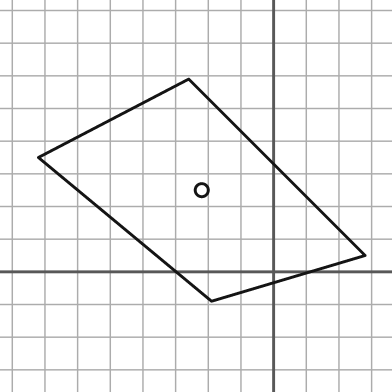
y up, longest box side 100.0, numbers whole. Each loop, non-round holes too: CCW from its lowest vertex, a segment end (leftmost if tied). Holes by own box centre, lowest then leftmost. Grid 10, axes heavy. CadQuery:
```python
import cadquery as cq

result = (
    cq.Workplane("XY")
    .moveTo(-19.0, -9.0)
    .lineTo(28.0, 5.0)
    .lineTo(-26.0, 59.0)
    .lineTo(-72.0, 35.0)
    .close()
    .moveTo(-22.0, 25.0)
    .circle(2.0)
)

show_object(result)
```